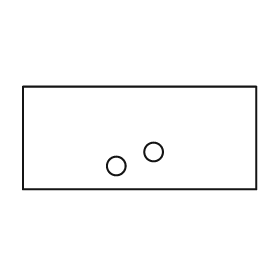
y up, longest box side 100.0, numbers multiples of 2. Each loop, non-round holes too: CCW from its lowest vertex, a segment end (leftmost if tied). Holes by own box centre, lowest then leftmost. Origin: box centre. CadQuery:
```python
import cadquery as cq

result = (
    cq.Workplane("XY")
    .moveTo(-50.0, -22.0)
    .lineTo(50.0, -22.0)
    .lineTo(50.0, 22.0)
    .lineTo(-50.0, 22.0)
    .close()
    .moveTo(-10.0, -12.0)
    .circle(4.0)
    .moveTo(6.0, -6.0)
    .circle(4.0)
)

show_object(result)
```